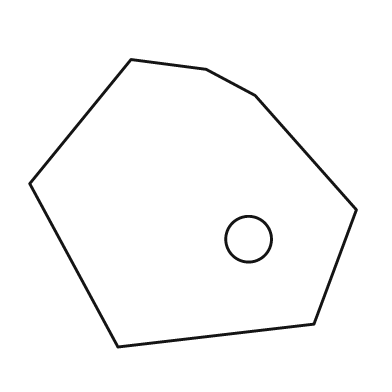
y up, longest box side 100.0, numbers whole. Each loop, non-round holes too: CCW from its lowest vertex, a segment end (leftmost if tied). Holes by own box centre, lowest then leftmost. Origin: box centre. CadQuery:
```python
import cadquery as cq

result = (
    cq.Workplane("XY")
    .moveTo(-23.0, -44.0)
    .lineTo(37.0, -37.0)
    .lineTo(50.0, -2.0)
    .lineTo(19.0, 33.0)
    .lineTo(4.0, 41.0)
    .lineTo(-19.0, 44.0)
    .lineTo(-50.0, 6.0)
    .close()
    .moveTo(17.0, -11.0)
    .circle(7.0)
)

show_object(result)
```